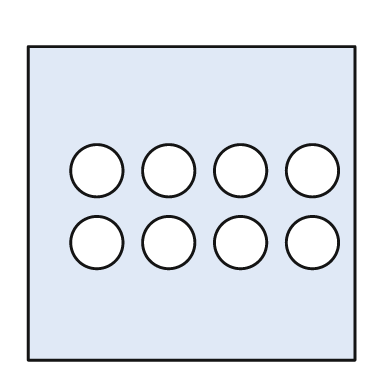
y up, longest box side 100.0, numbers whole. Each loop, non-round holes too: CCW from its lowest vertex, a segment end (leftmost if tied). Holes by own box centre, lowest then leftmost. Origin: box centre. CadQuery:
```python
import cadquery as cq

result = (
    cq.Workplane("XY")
    .moveTo(-50.0, -48.0)
    .lineTo(50.0, -48.0)
    .lineTo(50.0, 48.0)
    .lineTo(-50.0, 48.0)
    .close()
    .moveTo(-29.0, -12.0)
    .circle(8.0)
    .moveTo(-7.0, -12.0)
    .circle(8.0)
    .moveTo(15.0, -12.0)
    .circle(8.0)
    .moveTo(37.0, -12.0)
    .circle(8.0)
    .moveTo(-29.0, 10.0)
    .circle(8.0)
    .moveTo(-7.0, 10.0)
    .circle(8.0)
    .moveTo(15.0, 10.0)
    .circle(8.0)
    .moveTo(37.0, 10.0)
    .circle(8.0)
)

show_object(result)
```